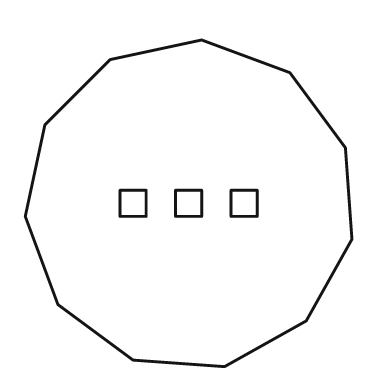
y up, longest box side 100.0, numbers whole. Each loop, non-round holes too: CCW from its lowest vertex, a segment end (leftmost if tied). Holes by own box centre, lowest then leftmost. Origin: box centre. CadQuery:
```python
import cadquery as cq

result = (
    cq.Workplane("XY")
    .moveTo(11.0, -50.0)
    .lineTo(36.0, -36.0)
    .lineTo(50.0, -11.0)
    .lineTo(48.0, 17.0)
    .lineTo(31.0, 40.0)
    .lineTo(4.0, 50.0)
    .lineTo(-24.0, 44.0)
    .lineTo(-44.0, 24.0)
    .lineTo(-50.0, -4.0)
    .lineTo(-40.0, -31.0)
    .lineTo(-17.0, -48.0)
    .close()
    .moveTo(-21.0, -4.0)
    .lineTo(-13.0, -4.0)
    .lineTo(-13.0, 4.0)
    .lineTo(-21.0, 4.0)
    .close()
    .moveTo(-4.0, -4.0)
    .lineTo(4.0, -4.0)
    .lineTo(4.0, 4.0)
    .lineTo(-4.0, 4.0)
    .close()
    .moveTo(13.0, -4.0)
    .lineTo(21.0, -4.0)
    .lineTo(21.0, 4.0)
    .lineTo(13.0, 4.0)
    .close()
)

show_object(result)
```